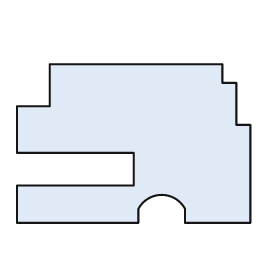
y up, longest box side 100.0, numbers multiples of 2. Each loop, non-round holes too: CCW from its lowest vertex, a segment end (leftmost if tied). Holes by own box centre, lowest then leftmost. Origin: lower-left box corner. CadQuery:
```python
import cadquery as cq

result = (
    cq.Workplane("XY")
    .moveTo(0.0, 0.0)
    .lineTo(52.0, 0.0)
    .lineTo(52.0, 6.0)
    .threePointArc((62.0, 12.0), (72.0, 6.0))
    .lineTo(72.0, 0.0)
    .lineTo(100.0, 0.0)
    .lineTo(100.0, 42.0)
    .lineTo(94.0, 42.0)
    .lineTo(94.0, 60.0)
    .lineTo(88.0, 60.0)
    .lineTo(88.0, 68.0)
    .lineTo(14.0, 68.0)
    .lineTo(14.0, 50.0)
    .lineTo(0.0, 50.0)
    .lineTo(0.0, 30.0)
    .lineTo(50.0, 30.0)
    .lineTo(50.0, 16.0)
    .lineTo(0.0, 16.0)
    .close()
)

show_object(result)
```